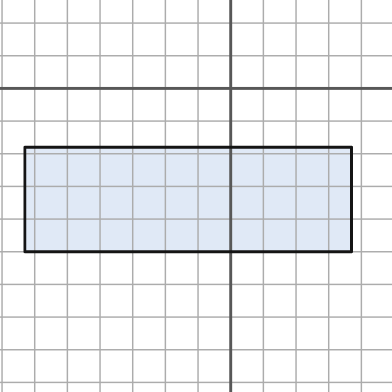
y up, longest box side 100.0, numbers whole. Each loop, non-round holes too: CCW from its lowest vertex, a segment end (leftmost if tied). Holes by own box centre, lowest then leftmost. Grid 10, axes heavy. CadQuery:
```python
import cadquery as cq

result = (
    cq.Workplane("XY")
    .moveTo(-63.0, -50.0)
    .lineTo(37.0, -50.0)
    .lineTo(37.0, -18.0)
    .lineTo(-63.0, -18.0)
    .close()
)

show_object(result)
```